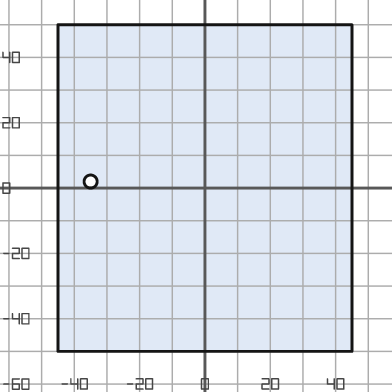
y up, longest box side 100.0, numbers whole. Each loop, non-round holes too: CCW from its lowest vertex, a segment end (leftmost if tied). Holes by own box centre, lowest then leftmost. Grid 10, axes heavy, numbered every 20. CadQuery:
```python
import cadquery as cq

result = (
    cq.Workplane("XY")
    .moveTo(-45.0, -50.0)
    .lineTo(45.0, -50.0)
    .lineTo(45.0, 50.0)
    .lineTo(-45.0, 50.0)
    .close()
    .moveTo(-35.0, 2.0)
    .circle(2.0)
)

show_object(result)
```